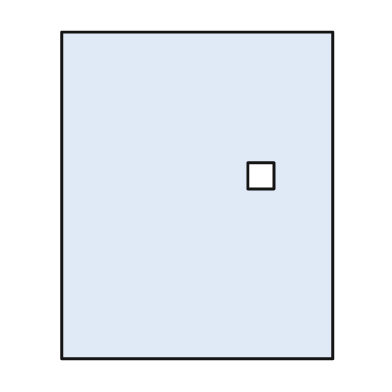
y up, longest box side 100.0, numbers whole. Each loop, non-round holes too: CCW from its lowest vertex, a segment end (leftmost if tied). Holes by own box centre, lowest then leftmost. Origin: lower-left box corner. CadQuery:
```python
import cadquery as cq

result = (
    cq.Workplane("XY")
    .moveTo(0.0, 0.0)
    .lineTo(83.0, 0.0)
    .lineTo(83.0, 100.0)
    .lineTo(0.0, 100.0)
    .close()
    .moveTo(57.0, 52.0)
    .lineTo(65.0, 52.0)
    .lineTo(65.0, 60.0)
    .lineTo(57.0, 60.0)
    .close()
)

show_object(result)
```